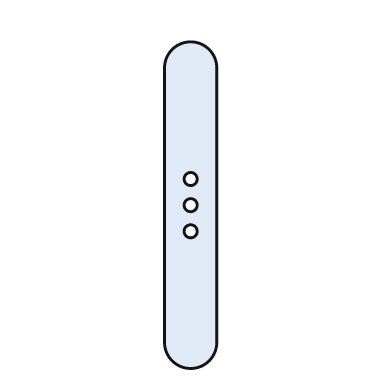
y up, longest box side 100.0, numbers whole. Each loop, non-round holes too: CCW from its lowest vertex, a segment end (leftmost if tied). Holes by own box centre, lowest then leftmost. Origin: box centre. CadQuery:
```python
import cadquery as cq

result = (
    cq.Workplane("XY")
    .moveTo(-8.0, -42.0)
    .threePointArc((0.0, -50.0), (8.0, -42.0))
    .lineTo(8.0, 42.0)
    .threePointArc((0.0, 50.0), (-8.0, 42.0))
    .close()
    .moveTo(0.0, -8.0)
    .circle(2.0)
    .moveTo(0.0, 0.0)
    .circle(2.0)
    .moveTo(0.0, 8.0)
    .circle(2.0)
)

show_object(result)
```